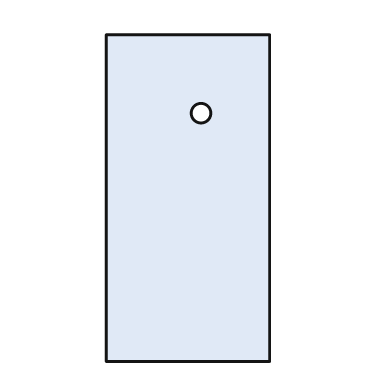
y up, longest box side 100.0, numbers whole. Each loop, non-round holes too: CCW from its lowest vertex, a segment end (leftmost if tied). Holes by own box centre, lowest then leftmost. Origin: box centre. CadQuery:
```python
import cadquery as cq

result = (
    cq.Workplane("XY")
    .moveTo(-25.0, -50.0)
    .lineTo(25.0, -50.0)
    .lineTo(25.0, 50.0)
    .lineTo(-25.0, 50.0)
    .close()
    .moveTo(4.0, 26.0)
    .circle(3.0)
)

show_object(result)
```